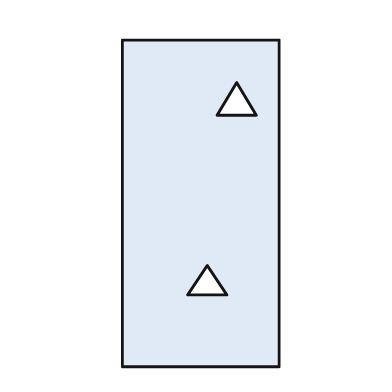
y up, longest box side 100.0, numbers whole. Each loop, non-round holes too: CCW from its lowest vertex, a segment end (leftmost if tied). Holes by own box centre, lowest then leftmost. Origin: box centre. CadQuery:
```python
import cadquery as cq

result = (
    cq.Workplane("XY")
    .moveTo(-24.0, -50.0)
    .lineTo(24.0, -50.0)
    .lineTo(24.0, 50.0)
    .lineTo(-24.0, 50.0)
    .close()
    .moveTo(-4.0, -28.0)
    .lineTo(8.0, -28.0)
    .lineTo(2.0, -19.0)
    .close()
    .moveTo(5.0, 27.0)
    .lineTo(17.0, 27.0)
    .lineTo(11.0, 37.0)
    .close()
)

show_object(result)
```